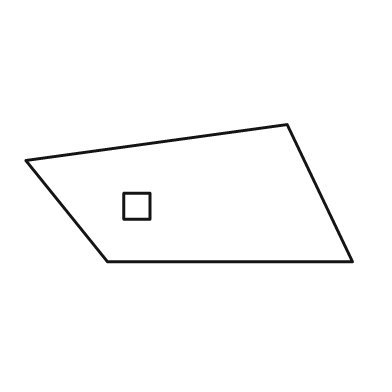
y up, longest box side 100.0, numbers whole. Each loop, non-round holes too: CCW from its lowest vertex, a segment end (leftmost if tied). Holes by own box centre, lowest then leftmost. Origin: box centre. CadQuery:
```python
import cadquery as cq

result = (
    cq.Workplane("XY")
    .moveTo(-25.0, -21.0)
    .lineTo(50.0, -21.0)
    .lineTo(30.0, 21.0)
    .lineTo(-50.0, 10.0)
    .close()
    .moveTo(-20.0, -8.0)
    .lineTo(-12.0, -8.0)
    .lineTo(-12.0, 0.0)
    .lineTo(-20.0, 0.0)
    .close()
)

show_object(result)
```